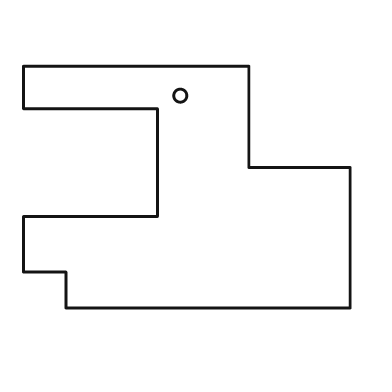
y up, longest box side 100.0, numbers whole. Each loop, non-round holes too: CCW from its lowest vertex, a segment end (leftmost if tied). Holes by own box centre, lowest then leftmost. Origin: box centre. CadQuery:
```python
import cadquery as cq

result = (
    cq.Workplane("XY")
    .moveTo(-37.0, -37.0)
    .lineTo(50.0, -37.0)
    .lineTo(50.0, 6.0)
    .lineTo(19.0, 6.0)
    .lineTo(19.0, 37.0)
    .lineTo(-50.0, 37.0)
    .lineTo(-50.0, 24.0)
    .lineTo(-9.0, 24.0)
    .lineTo(-9.0, -9.0)
    .lineTo(-50.0, -9.0)
    .lineTo(-50.0, -26.0)
    .lineTo(-37.0, -26.0)
    .close()
    .moveTo(-2.0, 28.0)
    .circle(2.0)
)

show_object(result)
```